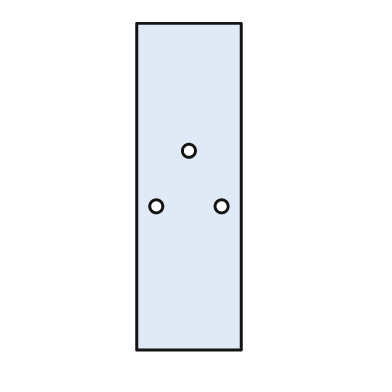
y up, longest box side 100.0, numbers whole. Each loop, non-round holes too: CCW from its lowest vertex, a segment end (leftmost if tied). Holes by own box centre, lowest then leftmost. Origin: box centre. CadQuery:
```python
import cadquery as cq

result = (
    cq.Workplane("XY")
    .moveTo(-16.0, -50.0)
    .lineTo(16.0, -50.0)
    .lineTo(16.0, 50.0)
    .lineTo(-16.0, 50.0)
    .close()
    .moveTo(-10.0, -6.0)
    .circle(2.0)
    .moveTo(10.0, -6.0)
    .circle(2.0)
    .moveTo(0.0, 11.0)
    .circle(2.0)
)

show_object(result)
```